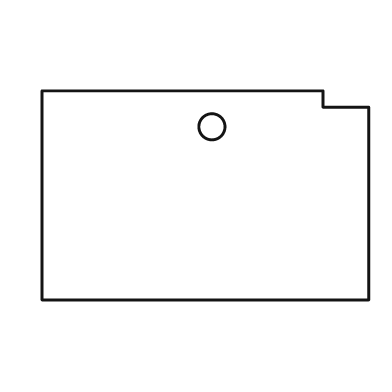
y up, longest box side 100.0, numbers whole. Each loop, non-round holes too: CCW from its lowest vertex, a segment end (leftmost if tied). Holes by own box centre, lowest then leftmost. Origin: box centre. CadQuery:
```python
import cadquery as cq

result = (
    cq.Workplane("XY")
    .moveTo(-50.0, -32.0)
    .lineTo(50.0, -32.0)
    .lineTo(50.0, 27.0)
    .lineTo(36.0, 27.0)
    .lineTo(36.0, 32.0)
    .lineTo(-50.0, 32.0)
    .close()
    .moveTo(2.0, 21.0)
    .circle(4.0)
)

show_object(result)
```